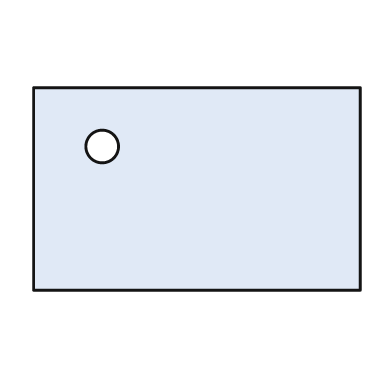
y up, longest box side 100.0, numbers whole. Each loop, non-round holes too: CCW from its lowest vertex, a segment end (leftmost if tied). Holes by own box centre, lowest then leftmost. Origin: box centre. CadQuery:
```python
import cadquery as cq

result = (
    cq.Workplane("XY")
    .moveTo(-50.0, -31.0)
    .lineTo(50.0, -31.0)
    .lineTo(50.0, 31.0)
    .lineTo(-50.0, 31.0)
    .close()
    .moveTo(-29.0, 13.0)
    .circle(5.0)
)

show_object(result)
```